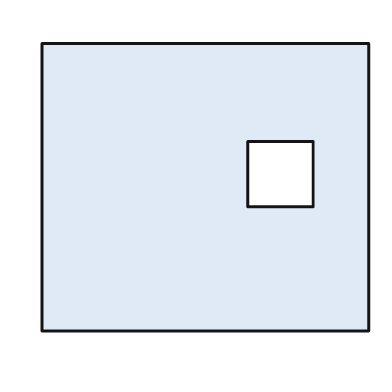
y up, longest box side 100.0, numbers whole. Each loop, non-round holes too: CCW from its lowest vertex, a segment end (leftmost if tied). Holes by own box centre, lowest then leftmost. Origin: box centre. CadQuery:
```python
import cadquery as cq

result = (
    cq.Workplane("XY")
    .moveTo(-50.0, -44.0)
    .lineTo(50.0, -44.0)
    .lineTo(50.0, 44.0)
    .lineTo(-50.0, 44.0)
    .close()
    .moveTo(13.0, -6.0)
    .lineTo(33.0, -6.0)
    .lineTo(33.0, 14.0)
    .lineTo(13.0, 14.0)
    .close()
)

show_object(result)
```